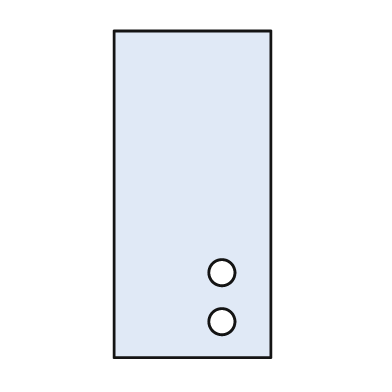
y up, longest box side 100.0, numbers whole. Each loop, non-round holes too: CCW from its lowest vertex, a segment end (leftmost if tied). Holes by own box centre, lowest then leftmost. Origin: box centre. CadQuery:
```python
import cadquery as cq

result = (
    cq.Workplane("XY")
    .moveTo(-24.0, -50.0)
    .lineTo(24.0, -50.0)
    .lineTo(24.0, 50.0)
    .lineTo(-24.0, 50.0)
    .close()
    .moveTo(9.0, -39.0)
    .circle(4.0)
    .moveTo(9.0, -24.0)
    .circle(4.0)
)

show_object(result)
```